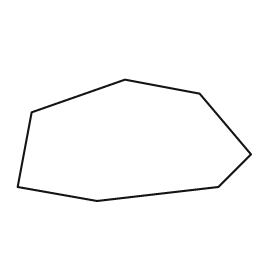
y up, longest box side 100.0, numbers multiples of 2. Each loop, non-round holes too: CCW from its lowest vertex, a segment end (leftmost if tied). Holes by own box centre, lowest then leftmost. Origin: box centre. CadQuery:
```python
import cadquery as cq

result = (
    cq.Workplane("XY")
    .moveTo(-16.0, -26.0)
    .lineTo(36.0, -20.0)
    .lineTo(50.0, -6.0)
    .lineTo(28.0, 20.0)
    .lineTo(-4.0, 26.0)
    .lineTo(-44.0, 12.0)
    .lineTo(-50.0, -20.0)
    .close()
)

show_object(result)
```